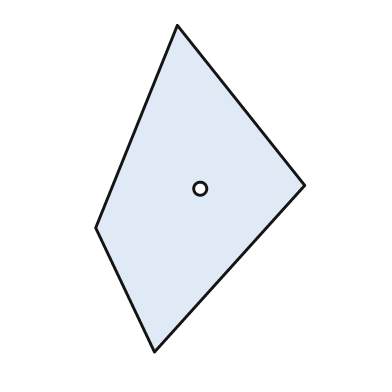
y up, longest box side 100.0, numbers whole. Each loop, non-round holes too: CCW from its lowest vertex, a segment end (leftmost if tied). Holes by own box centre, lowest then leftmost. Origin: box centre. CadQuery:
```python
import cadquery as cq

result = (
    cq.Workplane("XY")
    .moveTo(-14.0, -50.0)
    .lineTo(32.0, 1.0)
    .lineTo(-7.0, 50.0)
    .lineTo(-32.0, -12.0)
    .close()
    .moveTo(0.0, 0.0)
    .circle(2.0)
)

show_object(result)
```